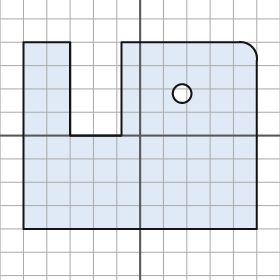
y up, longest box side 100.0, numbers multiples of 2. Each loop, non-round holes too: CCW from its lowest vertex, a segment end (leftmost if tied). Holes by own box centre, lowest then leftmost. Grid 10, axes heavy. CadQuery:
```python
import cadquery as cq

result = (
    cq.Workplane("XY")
    .moveTo(-50.0, -40.0)
    .lineTo(50.0, -40.0)
    .lineTo(50.0, 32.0)
    .threePointArc((48.0, 38.0), (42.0, 40.0))
    .lineTo(-8.0, 40.0)
    .lineTo(-8.0, 0.0)
    .lineTo(-30.0, 0.0)
    .lineTo(-30.0, 40.0)
    .lineTo(-50.0, 40.0)
    .close()
    .moveTo(18.0, 18.0)
    .circle(4.0)
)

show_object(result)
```